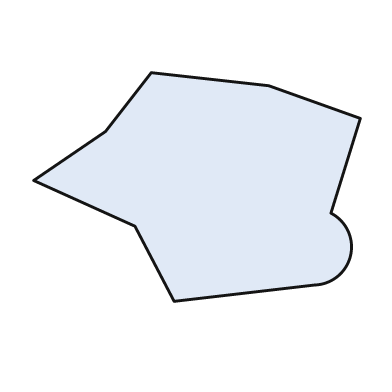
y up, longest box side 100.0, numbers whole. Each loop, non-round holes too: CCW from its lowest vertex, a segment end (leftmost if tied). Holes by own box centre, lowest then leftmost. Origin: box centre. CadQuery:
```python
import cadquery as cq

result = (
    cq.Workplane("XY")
    .moveTo(-7.0, -35.0)
    .lineTo(36.0, -30.0)
    .threePointArc((47.0, -21.0), (41.0, -8.0))
    .lineTo(50.0, 21.0)
    .lineTo(22.0, 31.0)
    .lineTo(-14.0, 35.0)
    .lineTo(-28.0, 17.0)
    .lineTo(-50.0, 2.0)
    .lineTo(-19.0, -12.0)
    .close()
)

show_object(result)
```